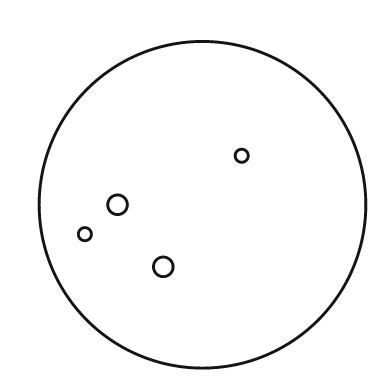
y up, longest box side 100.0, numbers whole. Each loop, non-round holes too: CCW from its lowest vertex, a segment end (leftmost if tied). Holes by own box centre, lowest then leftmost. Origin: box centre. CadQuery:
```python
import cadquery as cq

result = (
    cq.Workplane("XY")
    .moveTo(0.0, 0.0)
    .circle(50.0)
    .moveTo(-12.0, -19.0)
    .circle(3.0)
    .moveTo(-36.0, -9.0)
    .circle(2.0)
    .moveTo(-26.0, 0.0)
    .circle(3.0)
    .moveTo(12.0, 15.0)
    .circle(2.0)
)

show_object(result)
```